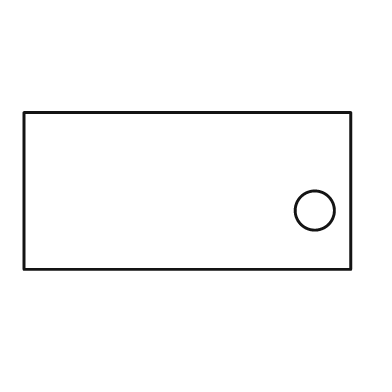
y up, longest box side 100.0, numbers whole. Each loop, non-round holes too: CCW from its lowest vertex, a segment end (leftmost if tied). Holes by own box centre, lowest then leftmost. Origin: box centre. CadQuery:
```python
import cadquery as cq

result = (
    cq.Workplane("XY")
    .moveTo(-50.0, -24.0)
    .lineTo(50.0, -24.0)
    .lineTo(50.0, 24.0)
    .lineTo(-50.0, 24.0)
    .close()
    .moveTo(39.0, -6.0)
    .circle(6.0)
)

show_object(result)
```